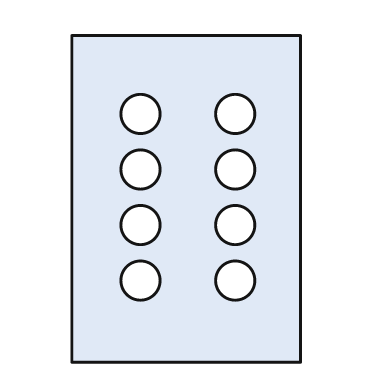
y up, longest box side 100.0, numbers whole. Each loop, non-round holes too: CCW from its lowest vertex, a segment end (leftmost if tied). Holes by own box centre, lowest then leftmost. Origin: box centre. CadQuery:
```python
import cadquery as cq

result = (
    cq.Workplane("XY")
    .moveTo(-35.0, -50.0)
    .lineTo(35.0, -50.0)
    .lineTo(35.0, 50.0)
    .lineTo(-35.0, 50.0)
    .close()
    .moveTo(-14.0, -25.0)
    .circle(6.0)
    .moveTo(15.0, -25.0)
    .circle(6.0)
    .moveTo(-14.0, -8.0)
    .circle(6.0)
    .moveTo(15.0, -8.0)
    .circle(6.0)
    .moveTo(-14.0, 9.0)
    .circle(6.0)
    .moveTo(15.0, 9.0)
    .circle(6.0)
    .moveTo(-14.0, 26.0)
    .circle(6.0)
    .moveTo(15.0, 26.0)
    .circle(6.0)
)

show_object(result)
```